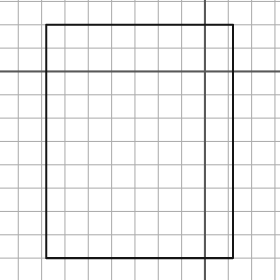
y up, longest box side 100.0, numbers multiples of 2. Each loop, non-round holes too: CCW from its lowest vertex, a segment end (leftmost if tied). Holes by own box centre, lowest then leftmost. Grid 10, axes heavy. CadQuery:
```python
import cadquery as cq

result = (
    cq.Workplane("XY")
    .moveTo(-68.0, -80.0)
    .lineTo(12.0, -80.0)
    .lineTo(12.0, 20.0)
    .lineTo(-68.0, 20.0)
    .close()
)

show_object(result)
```